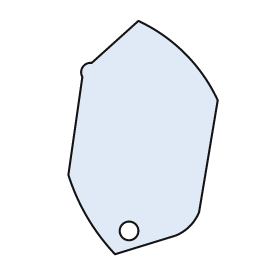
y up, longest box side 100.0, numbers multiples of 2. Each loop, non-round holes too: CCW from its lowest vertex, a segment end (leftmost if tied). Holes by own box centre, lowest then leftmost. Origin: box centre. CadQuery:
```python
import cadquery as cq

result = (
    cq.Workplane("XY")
    .moveTo(-12.0, -50.0)
    .lineTo(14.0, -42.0)
    .threePointArc((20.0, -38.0), (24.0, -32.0))
    .lineTo(32.0, 16.0)
    .threePointArc((18.0, 36.0), (-2.0, 50.0))
    .lineTo(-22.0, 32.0)
    .threePointArc((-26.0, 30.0), (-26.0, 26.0))
    .lineTo(-32.0, -16.0)
    .threePointArc((-24.0, -34.0), (-12.0, -50.0))
    .close()
    .moveTo(-6.0, -40.0)
    .circle(4.0)
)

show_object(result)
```